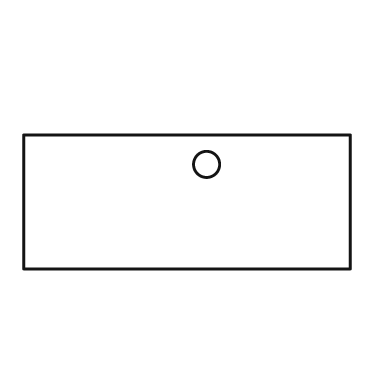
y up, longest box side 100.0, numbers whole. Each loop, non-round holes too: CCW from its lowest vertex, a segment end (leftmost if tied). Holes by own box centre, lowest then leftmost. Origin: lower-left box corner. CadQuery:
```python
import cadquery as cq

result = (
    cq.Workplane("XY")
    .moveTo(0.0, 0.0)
    .lineTo(100.0, 0.0)
    .lineTo(100.0, 41.0)
    .lineTo(0.0, 41.0)
    .close()
    .moveTo(56.0, 32.0)
    .circle(4.0)
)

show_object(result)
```